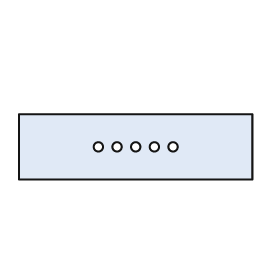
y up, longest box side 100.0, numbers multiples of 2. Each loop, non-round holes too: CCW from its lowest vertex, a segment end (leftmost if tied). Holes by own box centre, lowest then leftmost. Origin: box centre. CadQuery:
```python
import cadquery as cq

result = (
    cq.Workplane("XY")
    .moveTo(-50.0, -14.0)
    .lineTo(50.0, -14.0)
    .lineTo(50.0, 14.0)
    .lineTo(-50.0, 14.0)
    .close()
    .moveTo(-16.0, 0.0)
    .circle(2.0)
    .moveTo(-8.0, 0.0)
    .circle(2.0)
    .moveTo(0.0, 0.0)
    .circle(2.0)
    .moveTo(8.0, 0.0)
    .circle(2.0)
    .moveTo(16.0, 0.0)
    .circle(2.0)
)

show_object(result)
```